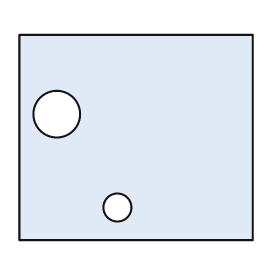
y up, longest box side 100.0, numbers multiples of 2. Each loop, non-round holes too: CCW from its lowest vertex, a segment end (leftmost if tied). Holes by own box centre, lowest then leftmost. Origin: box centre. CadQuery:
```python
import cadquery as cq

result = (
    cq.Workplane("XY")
    .moveTo(-50.0, -44.0)
    .lineTo(50.0, -44.0)
    .lineTo(50.0, 44.0)
    .lineTo(-50.0, 44.0)
    .close()
    .moveTo(-8.0, -30.0)
    .circle(6.0)
    .moveTo(-34.0, 10.0)
    .circle(10.0)
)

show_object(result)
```